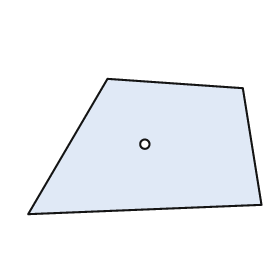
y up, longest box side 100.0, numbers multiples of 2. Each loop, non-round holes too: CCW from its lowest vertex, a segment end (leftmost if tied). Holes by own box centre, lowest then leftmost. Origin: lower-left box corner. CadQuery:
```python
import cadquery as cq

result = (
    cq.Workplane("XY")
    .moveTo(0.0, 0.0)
    .lineTo(100.0, 4.0)
    .lineTo(92.0, 54.0)
    .lineTo(34.0, 58.0)
    .close()
    .moveTo(50.0, 30.0)
    .circle(2.0)
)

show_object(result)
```